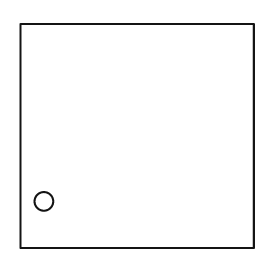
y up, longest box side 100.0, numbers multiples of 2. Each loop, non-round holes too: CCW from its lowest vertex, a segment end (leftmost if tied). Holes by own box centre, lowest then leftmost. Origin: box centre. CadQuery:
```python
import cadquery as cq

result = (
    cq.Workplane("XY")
    .moveTo(-50.0, -48.0)
    .lineTo(50.0, -48.0)
    .lineTo(50.0, 48.0)
    .lineTo(-50.0, 48.0)
    .close()
    .moveTo(-40.0, -28.0)
    .circle(4.0)
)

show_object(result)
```